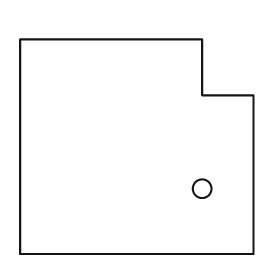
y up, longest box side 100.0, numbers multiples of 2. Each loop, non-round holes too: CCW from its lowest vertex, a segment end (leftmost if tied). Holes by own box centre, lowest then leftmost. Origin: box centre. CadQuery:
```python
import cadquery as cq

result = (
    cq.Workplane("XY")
    .moveTo(-50.0, -46.0)
    .lineTo(50.0, -46.0)
    .lineTo(50.0, 22.0)
    .lineTo(28.0, 22.0)
    .lineTo(28.0, 46.0)
    .lineTo(-50.0, 46.0)
    .close()
    .moveTo(28.0, -18.0)
    .circle(4.0)
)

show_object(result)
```